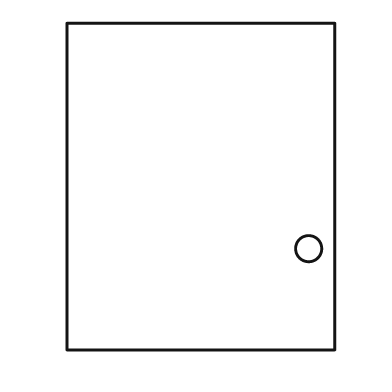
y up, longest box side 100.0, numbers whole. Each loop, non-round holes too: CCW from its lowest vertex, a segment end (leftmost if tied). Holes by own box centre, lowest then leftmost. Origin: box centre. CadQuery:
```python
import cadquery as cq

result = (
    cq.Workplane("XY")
    .moveTo(-41.0, -50.0)
    .lineTo(41.0, -50.0)
    .lineTo(41.0, 50.0)
    .lineTo(-41.0, 50.0)
    .close()
    .moveTo(33.0, -19.0)
    .circle(4.0)
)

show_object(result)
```